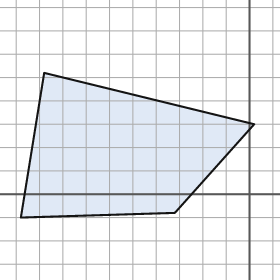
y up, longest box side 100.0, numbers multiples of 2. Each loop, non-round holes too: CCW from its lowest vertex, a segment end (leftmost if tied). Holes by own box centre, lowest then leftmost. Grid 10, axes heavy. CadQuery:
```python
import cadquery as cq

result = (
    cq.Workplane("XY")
    .moveTo(-98.0, -10.0)
    .lineTo(-32.0, -8.0)
    .lineTo(2.0, 30.0)
    .lineTo(-88.0, 52.0)
    .close()
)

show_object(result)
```